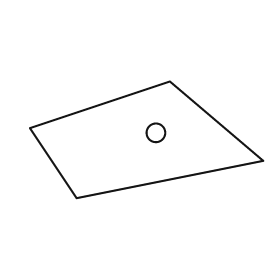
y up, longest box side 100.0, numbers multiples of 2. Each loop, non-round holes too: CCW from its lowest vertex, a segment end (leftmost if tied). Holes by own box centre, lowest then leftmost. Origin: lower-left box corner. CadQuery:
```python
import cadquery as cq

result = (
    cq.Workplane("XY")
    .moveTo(20.0, 0.0)
    .lineTo(100.0, 16.0)
    .lineTo(60.0, 50.0)
    .lineTo(0.0, 30.0)
    .close()
    .moveTo(54.0, 28.0)
    .circle(4.0)
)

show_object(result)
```